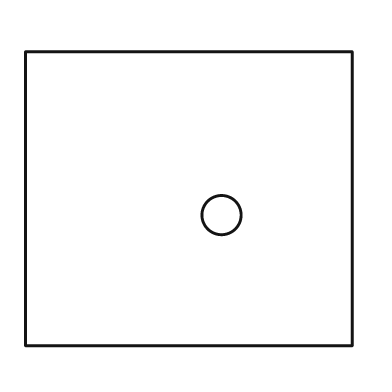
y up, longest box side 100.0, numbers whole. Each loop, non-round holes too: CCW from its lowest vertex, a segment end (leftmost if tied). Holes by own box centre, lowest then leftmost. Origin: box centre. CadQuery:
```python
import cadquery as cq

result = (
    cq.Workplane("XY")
    .moveTo(-50.0, -45.0)
    .lineTo(50.0, -45.0)
    .lineTo(50.0, 45.0)
    .lineTo(-50.0, 45.0)
    .close()
    .moveTo(10.0, -5.0)
    .circle(6.0)
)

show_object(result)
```